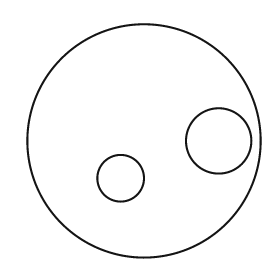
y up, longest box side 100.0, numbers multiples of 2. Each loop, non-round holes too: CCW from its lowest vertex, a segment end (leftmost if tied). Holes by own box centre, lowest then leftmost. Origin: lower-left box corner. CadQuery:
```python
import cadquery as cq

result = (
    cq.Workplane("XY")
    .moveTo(50.0, 50.0)
    .circle(50.0)
    .moveTo(40.0, 34.0)
    .circle(10.0)
    .moveTo(82.0, 50.0)
    .circle(14.0)
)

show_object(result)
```